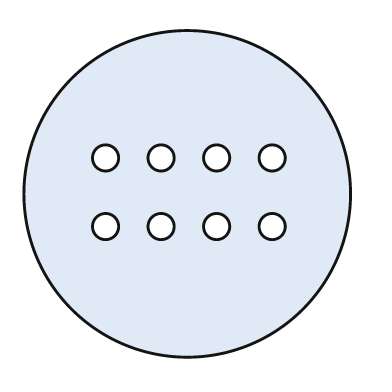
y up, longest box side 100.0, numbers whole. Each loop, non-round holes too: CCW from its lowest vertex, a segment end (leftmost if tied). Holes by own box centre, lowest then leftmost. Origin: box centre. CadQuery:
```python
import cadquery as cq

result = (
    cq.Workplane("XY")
    .moveTo(0.0, 0.0)
    .circle(50.0)
    .moveTo(-25.0, -10.0)
    .circle(4.0)
    .moveTo(-8.0, -10.0)
    .circle(4.0)
    .moveTo(9.0, -10.0)
    .circle(4.0)
    .moveTo(26.0, -10.0)
    .circle(4.0)
    .moveTo(-25.0, 11.0)
    .circle(4.0)
    .moveTo(-8.0, 11.0)
    .circle(4.0)
    .moveTo(9.0, 11.0)
    .circle(4.0)
    .moveTo(26.0, 11.0)
    .circle(4.0)
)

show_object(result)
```